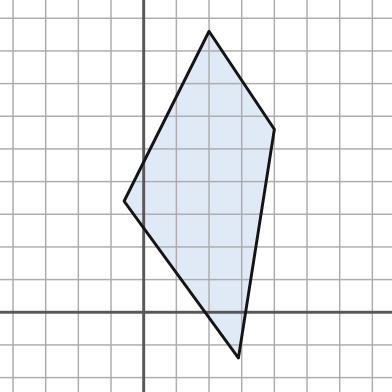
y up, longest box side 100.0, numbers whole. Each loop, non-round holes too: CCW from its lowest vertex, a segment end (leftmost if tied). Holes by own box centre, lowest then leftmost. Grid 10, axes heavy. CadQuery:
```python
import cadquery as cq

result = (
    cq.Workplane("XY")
    .moveTo(29.0, -14.0)
    .lineTo(40.0, 56.0)
    .lineTo(20.0, 86.0)
    .lineTo(-6.0, 34.0)
    .close()
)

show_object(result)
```